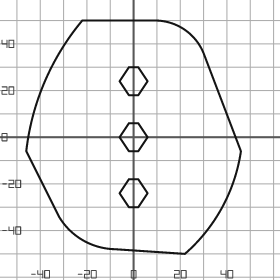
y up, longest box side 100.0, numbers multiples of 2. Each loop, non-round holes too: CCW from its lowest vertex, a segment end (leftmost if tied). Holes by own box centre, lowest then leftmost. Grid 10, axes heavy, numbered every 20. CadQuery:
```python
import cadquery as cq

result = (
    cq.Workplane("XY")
    .moveTo(22.0, -50.0)
    .threePointArc((38.0, -30.0), (46.0, -6.0))
    .lineTo(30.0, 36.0)
    .threePointArc((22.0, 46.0), (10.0, 50.0))
    .lineTo(-22.0, 50.0)
    .threePointArc((-38.0, 24.0), (-46.0, -6.0))
    .lineTo(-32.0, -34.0)
    .threePointArc((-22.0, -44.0), (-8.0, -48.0))
    .close()
    .moveTo(-2.0, -30.0)
    .lineTo(2.0, -30.0)
    .lineTo(6.0, -24.0)
    .lineTo(2.0, -18.0)
    .lineTo(-2.0, -18.0)
    .lineTo(-6.0, -24.0)
    .close()
    .moveTo(-2.0, -6.0)
    .lineTo(2.0, -6.0)
    .lineTo(6.0, 0.0)
    .lineTo(2.0, 6.0)
    .lineTo(-2.0, 6.0)
    .lineTo(-6.0, 0.0)
    .close()
    .moveTo(-2.0, 18.0)
    .lineTo(2.0, 18.0)
    .lineTo(6.0, 24.0)
    .lineTo(2.0, 30.0)
    .lineTo(-2.0, 30.0)
    .lineTo(-6.0, 24.0)
    .close()
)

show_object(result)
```